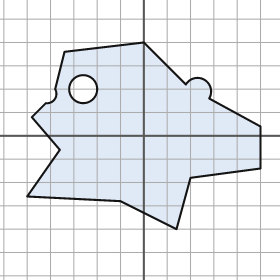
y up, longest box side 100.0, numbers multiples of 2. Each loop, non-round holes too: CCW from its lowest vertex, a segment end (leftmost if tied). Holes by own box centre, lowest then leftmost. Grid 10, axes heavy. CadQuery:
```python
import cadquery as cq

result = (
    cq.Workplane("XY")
    .moveTo(14.0, -40.0)
    .lineTo(20.0, -18.0)
    .lineTo(50.0, -14.0)
    .lineTo(50.0, 4.0)
    .lineTo(28.0, 16.0)
    .threePointArc((26.0, 24.0), (18.0, 22.0))
    .lineTo(0.0, 40.0)
    .lineTo(-34.0, 36.0)
    .lineTo(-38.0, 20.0)
    .threePointArc((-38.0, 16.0), (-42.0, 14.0))
    .lineTo(-48.0, 8.0)
    .lineTo(-36.0, -6.0)
    .lineTo(-50.0, -26.0)
    .lineTo(-10.0, -28.0)
    .close()
    .moveTo(-26.0, 20.0)
    .circle(6.0)
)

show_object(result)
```